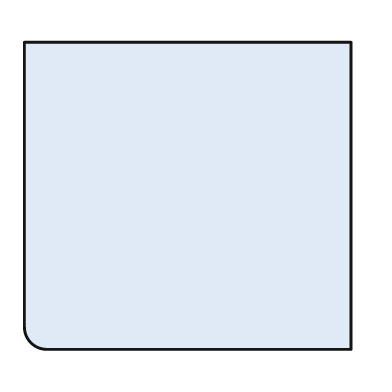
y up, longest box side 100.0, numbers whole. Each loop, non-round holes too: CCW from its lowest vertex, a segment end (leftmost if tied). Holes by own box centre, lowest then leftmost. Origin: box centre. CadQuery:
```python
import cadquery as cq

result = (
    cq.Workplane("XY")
    .moveTo(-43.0, -47.0)
    .lineTo(50.0, -47.0)
    .lineTo(50.0, 47.0)
    .lineTo(-50.0, 47.0)
    .lineTo(-50.0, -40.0)
    .threePointArc((-48.0, -45.0), (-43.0, -47.0))
    .close()
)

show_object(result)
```